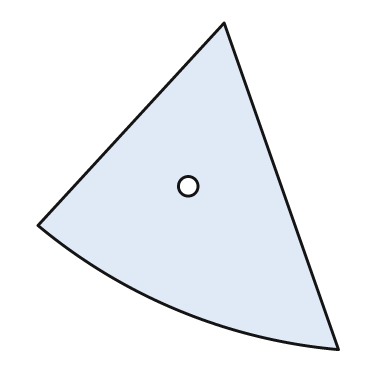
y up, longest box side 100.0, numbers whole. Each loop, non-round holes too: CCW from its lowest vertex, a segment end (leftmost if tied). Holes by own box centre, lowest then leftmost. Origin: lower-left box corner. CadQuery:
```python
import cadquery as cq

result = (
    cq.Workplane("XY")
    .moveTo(92.0, 0.0)
    .lineTo(57.0, 100.0)
    .lineTo(0.0, 38.0)
    .threePointArc((43.0, 12.0), (92.0, 0.0))
    .close()
    .moveTo(46.0, 50.0)
    .circle(3.0)
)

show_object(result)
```